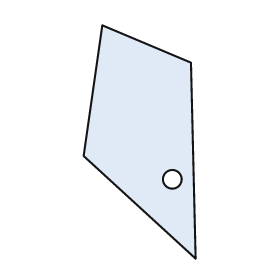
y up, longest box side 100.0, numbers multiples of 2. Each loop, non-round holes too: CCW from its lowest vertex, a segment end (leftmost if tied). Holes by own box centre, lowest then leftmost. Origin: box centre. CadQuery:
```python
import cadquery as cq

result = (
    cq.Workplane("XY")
    .moveTo(24.0, -50.0)
    .lineTo(22.0, 34.0)
    .lineTo(-16.0, 50.0)
    .lineTo(-24.0, -6.0)
    .close()
    .moveTo(14.0, -16.0)
    .circle(4.0)
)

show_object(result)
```